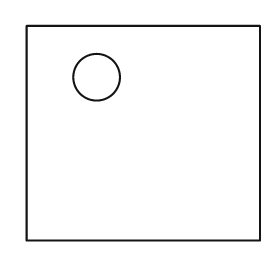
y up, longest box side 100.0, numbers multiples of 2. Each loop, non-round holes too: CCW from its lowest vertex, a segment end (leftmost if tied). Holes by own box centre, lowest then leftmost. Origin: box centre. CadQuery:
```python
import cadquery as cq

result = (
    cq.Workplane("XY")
    .moveTo(-50.0, -46.0)
    .lineTo(50.0, -46.0)
    .lineTo(50.0, 46.0)
    .lineTo(-50.0, 46.0)
    .close()
    .moveTo(-20.0, 24.0)
    .circle(10.0)
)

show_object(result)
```